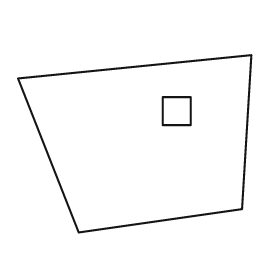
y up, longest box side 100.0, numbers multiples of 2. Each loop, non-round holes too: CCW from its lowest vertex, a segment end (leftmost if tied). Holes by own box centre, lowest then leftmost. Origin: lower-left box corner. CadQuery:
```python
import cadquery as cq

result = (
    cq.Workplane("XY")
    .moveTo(26.0, 0.0)
    .lineTo(96.0, 10.0)
    .lineTo(100.0, 76.0)
    .lineTo(0.0, 66.0)
    .close()
    .moveTo(62.0, 46.0)
    .lineTo(74.0, 46.0)
    .lineTo(74.0, 58.0)
    .lineTo(62.0, 58.0)
    .close()
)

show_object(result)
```